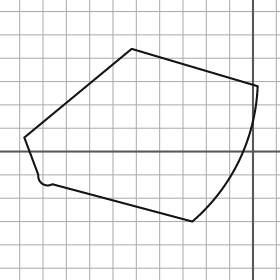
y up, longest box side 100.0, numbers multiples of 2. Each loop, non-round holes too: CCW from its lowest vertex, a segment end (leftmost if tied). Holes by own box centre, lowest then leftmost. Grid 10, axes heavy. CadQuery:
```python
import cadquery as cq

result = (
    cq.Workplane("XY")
    .moveTo(-26.0, -30.0)
    .threePointArc((-6.0, -4.0), (2.0, 28.0))
    .lineTo(-52.0, 44.0)
    .lineTo(-98.0, 6.0)
    .lineTo(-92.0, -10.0)
    .threePointArc((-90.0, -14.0), (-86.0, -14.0))
    .close()
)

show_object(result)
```